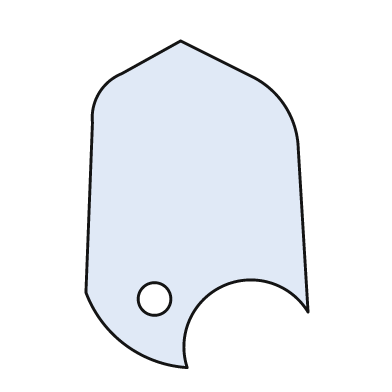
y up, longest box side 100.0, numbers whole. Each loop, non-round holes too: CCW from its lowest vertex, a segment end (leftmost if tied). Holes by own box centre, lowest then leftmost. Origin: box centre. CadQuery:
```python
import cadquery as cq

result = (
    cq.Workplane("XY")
    .moveTo(-3.0, -50.0)
    .threePointArc((8.0, -25.0), (34.0, -33.0))
    .lineTo(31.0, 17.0)
    .threePointArc((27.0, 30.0), (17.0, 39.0))
    .lineTo(-5.0, 50.0)
    .lineTo(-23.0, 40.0)
    .threePointArc((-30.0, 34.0), (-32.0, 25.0))
    .lineTo(-34.0, -27.0)
    .threePointArc((-22.0, -43.0), (-3.0, -50.0))
    .close()
    .moveTo(-13.0, -29.0)
    .circle(5.0)
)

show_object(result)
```